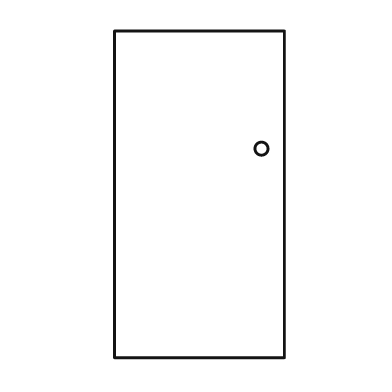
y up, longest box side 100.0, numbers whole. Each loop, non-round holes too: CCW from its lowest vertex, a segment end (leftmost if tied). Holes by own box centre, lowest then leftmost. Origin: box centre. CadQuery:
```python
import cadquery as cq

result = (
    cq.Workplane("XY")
    .moveTo(-26.0, -50.0)
    .lineTo(26.0, -50.0)
    .lineTo(26.0, 50.0)
    .lineTo(-26.0, 50.0)
    .close()
    .moveTo(19.0, 14.0)
    .circle(2.0)
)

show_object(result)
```